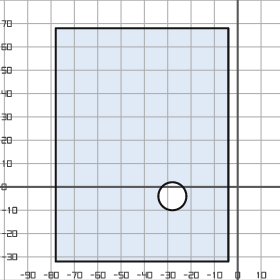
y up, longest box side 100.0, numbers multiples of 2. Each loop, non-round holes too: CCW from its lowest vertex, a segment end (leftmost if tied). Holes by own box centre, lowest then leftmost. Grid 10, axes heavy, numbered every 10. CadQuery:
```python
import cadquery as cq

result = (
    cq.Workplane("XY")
    .moveTo(-78.0, -32.0)
    .lineTo(-4.0, -32.0)
    .lineTo(-4.0, 68.0)
    .lineTo(-78.0, 68.0)
    .close()
    .moveTo(-28.0, -4.0)
    .circle(6.0)
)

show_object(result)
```